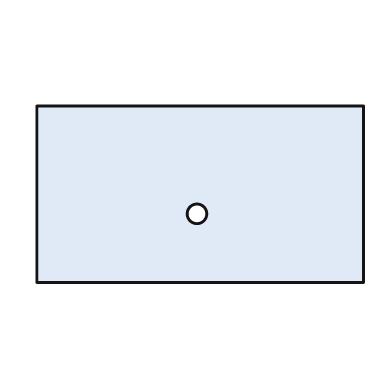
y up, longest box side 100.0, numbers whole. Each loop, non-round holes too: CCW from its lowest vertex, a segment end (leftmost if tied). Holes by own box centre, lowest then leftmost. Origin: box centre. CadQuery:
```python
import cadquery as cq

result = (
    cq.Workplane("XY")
    .moveTo(-50.0, -27.0)
    .lineTo(50.0, -27.0)
    .lineTo(50.0, 27.0)
    .lineTo(-50.0, 27.0)
    .close()
    .moveTo(-1.0, -6.0)
    .circle(3.0)
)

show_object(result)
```